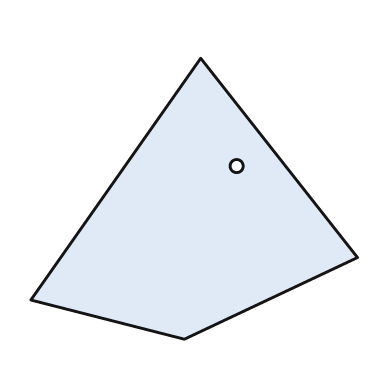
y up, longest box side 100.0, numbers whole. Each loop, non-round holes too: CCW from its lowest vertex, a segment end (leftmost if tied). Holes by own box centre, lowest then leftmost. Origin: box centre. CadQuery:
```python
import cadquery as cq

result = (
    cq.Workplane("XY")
    .moveTo(-3.0, -43.0)
    .lineTo(50.0, -18.0)
    .lineTo(2.0, 43.0)
    .lineTo(-50.0, -31.0)
    .close()
    .moveTo(13.0, 10.0)
    .circle(2.0)
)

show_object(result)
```